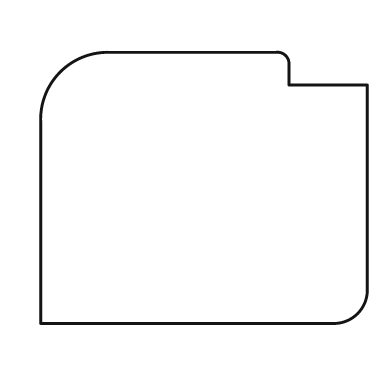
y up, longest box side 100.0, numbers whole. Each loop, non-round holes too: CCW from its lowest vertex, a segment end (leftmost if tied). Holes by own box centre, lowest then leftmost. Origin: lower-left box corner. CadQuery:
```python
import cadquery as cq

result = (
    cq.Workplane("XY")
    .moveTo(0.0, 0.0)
    .lineTo(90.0, 0.0)
    .threePointArc((97.0, 3.0), (100.0, 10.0))
    .lineTo(100.0, 73.0)
    .lineTo(76.0, 73.0)
    .lineTo(76.0, 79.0)
    .threePointArc((75.0, 82.0), (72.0, 83.0))
    .lineTo(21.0, 83.0)
    .threePointArc((6.0, 77.0), (0.0, 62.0))
    .close()
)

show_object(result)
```